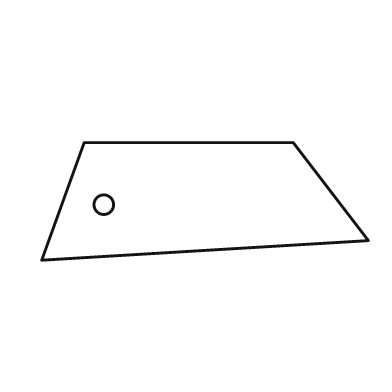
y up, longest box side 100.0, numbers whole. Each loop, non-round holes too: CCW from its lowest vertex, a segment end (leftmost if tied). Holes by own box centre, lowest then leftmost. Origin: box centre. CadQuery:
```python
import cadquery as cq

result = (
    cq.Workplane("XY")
    .moveTo(-50.0, -18.0)
    .lineTo(50.0, -12.0)
    .lineTo(27.0, 18.0)
    .lineTo(-37.0, 18.0)
    .close()
    .moveTo(-31.0, -1.0)
    .circle(3.0)
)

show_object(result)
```